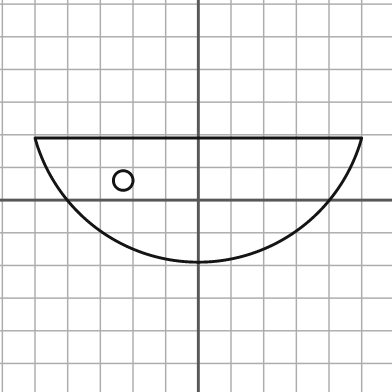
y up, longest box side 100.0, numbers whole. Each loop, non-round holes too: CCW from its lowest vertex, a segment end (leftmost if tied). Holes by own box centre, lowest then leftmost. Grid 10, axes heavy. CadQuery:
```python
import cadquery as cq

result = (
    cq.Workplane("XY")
    .moveTo(-50.0, 19.0)
    .threePointArc((0.0, -19.0), (50.0, 19.0))
    .close()
    .moveTo(-23.0, 6.0)
    .circle(3.0)
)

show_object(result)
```